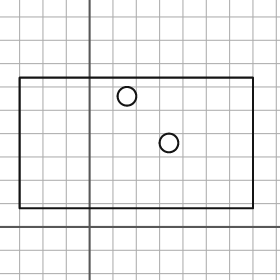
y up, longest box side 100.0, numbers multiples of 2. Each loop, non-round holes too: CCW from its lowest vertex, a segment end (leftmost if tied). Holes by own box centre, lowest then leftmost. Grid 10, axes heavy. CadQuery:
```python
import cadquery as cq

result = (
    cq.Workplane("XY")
    .moveTo(-30.0, 8.0)
    .lineTo(70.0, 8.0)
    .lineTo(70.0, 64.0)
    .lineTo(-30.0, 64.0)
    .close()
    .moveTo(34.0, 36.0)
    .circle(4.0)
    .moveTo(16.0, 56.0)
    .circle(4.0)
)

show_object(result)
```